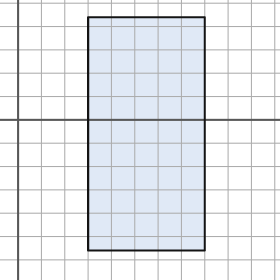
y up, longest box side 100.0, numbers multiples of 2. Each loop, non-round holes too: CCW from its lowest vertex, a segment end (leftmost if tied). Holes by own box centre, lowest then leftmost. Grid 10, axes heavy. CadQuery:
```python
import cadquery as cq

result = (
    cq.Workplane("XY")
    .moveTo(30.0, -56.0)
    .lineTo(80.0, -56.0)
    .lineTo(80.0, 44.0)
    .lineTo(30.0, 44.0)
    .close()
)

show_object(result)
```